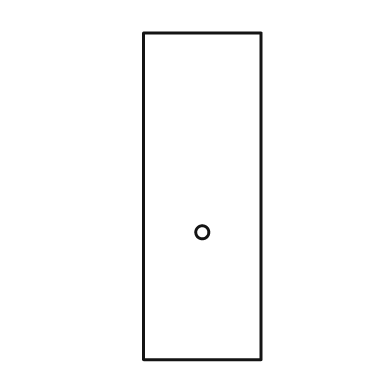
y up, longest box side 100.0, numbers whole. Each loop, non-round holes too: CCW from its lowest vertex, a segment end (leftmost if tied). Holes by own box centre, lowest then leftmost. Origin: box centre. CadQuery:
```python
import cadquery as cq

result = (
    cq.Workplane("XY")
    .moveTo(-18.0, -50.0)
    .lineTo(18.0, -50.0)
    .lineTo(18.0, 50.0)
    .lineTo(-18.0, 50.0)
    .close()
    .moveTo(0.0, -11.0)
    .circle(2.0)
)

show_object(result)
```